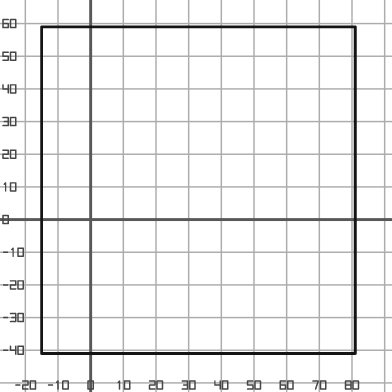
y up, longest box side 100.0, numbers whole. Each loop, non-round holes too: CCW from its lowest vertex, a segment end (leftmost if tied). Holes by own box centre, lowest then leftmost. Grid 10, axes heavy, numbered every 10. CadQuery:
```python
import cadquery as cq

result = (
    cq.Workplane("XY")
    .moveTo(-15.0, -41.0)
    .lineTo(81.0, -41.0)
    .lineTo(81.0, 59.0)
    .lineTo(-15.0, 59.0)
    .close()
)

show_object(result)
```